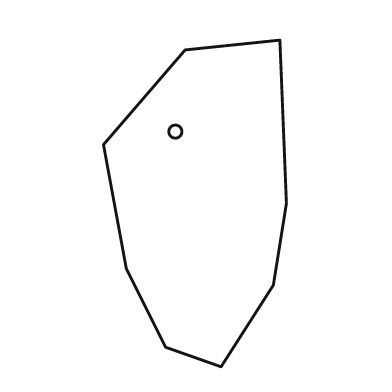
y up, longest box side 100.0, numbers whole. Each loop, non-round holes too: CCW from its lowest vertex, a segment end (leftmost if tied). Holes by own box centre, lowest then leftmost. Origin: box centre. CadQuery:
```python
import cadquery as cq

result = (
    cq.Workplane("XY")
    .moveTo(8.0, -50.0)
    .lineTo(24.0, -25.0)
    .lineTo(28.0, 0.0)
    .lineTo(26.0, 50.0)
    .lineTo(-3.0, 47.0)
    .lineTo(-28.0, 18.0)
    .lineTo(-21.0, -20.0)
    .lineTo(-9.0, -44.0)
    .close()
    .moveTo(-6.0, 22.0)
    .circle(2.0)
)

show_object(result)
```